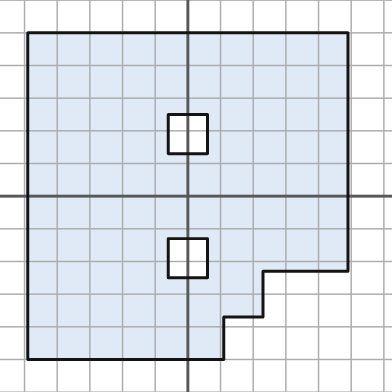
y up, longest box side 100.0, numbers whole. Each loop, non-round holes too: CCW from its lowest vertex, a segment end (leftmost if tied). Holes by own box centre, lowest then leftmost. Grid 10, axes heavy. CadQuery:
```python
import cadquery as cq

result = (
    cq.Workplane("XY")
    .moveTo(-49.0, -50.0)
    .lineTo(11.0, -50.0)
    .lineTo(11.0, -37.0)
    .lineTo(23.0, -37.0)
    .lineTo(23.0, -23.0)
    .lineTo(49.0, -23.0)
    .lineTo(49.0, 50.0)
    .lineTo(-49.0, 50.0)
    .close()
    .moveTo(-6.0, -25.0)
    .lineTo(6.0, -25.0)
    .lineTo(6.0, -13.0)
    .lineTo(-6.0, -13.0)
    .close()
    .moveTo(-6.0, 13.0)
    .lineTo(6.0, 13.0)
    .lineTo(6.0, 25.0)
    .lineTo(-6.0, 25.0)
    .close()
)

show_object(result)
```